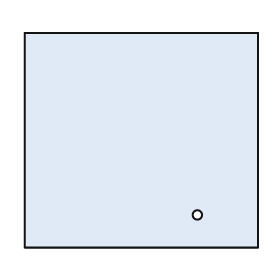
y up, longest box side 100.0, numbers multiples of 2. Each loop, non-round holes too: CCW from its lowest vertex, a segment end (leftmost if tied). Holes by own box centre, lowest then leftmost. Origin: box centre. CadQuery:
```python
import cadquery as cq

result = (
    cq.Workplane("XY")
    .moveTo(-50.0, -46.0)
    .lineTo(50.0, -46.0)
    .lineTo(50.0, 46.0)
    .lineTo(-50.0, 46.0)
    .close()
    .moveTo(24.0, -32.0)
    .circle(2.0)
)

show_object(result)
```